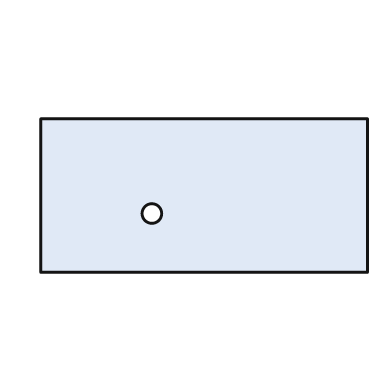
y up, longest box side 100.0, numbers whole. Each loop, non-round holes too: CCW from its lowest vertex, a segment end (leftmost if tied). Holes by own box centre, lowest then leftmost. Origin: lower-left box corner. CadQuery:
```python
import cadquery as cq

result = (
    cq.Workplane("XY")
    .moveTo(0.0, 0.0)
    .lineTo(100.0, 0.0)
    .lineTo(100.0, 47.0)
    .lineTo(0.0, 47.0)
    .close()
    .moveTo(34.0, 18.0)
    .circle(3.0)
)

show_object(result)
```